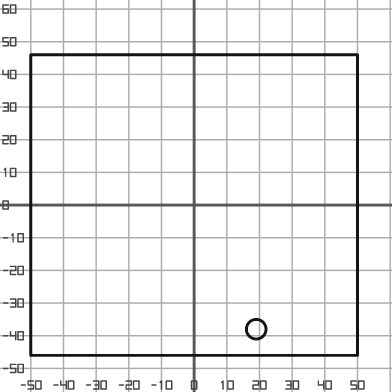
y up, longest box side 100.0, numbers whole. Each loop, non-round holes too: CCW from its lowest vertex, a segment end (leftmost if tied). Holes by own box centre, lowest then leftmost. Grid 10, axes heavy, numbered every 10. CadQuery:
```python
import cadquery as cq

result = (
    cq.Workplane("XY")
    .moveTo(-50.0, -46.0)
    .lineTo(50.0, -46.0)
    .lineTo(50.0, 46.0)
    .lineTo(-50.0, 46.0)
    .close()
    .moveTo(19.0, -38.0)
    .circle(3.0)
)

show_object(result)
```